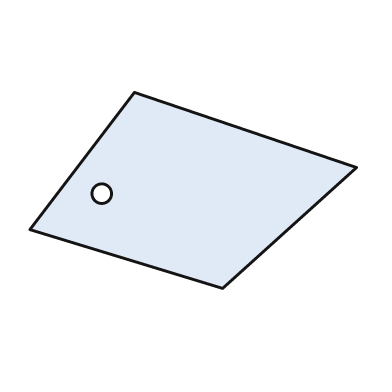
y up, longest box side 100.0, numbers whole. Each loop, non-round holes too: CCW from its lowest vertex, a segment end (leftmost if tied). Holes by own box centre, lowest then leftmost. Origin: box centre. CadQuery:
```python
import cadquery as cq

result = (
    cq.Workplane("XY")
    .moveTo(9.0, -30.0)
    .lineTo(50.0, 7.0)
    .lineTo(-18.0, 30.0)
    .lineTo(-50.0, -12.0)
    .close()
    .moveTo(-28.0, -1.0)
    .circle(3.0)
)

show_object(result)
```